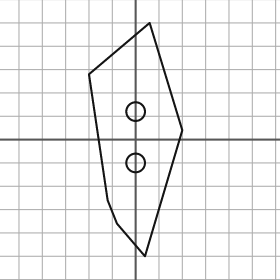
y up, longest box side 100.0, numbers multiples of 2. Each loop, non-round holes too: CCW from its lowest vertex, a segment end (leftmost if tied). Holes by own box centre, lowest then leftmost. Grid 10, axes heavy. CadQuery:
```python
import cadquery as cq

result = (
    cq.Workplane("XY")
    .moveTo(4.0, -50.0)
    .lineTo(20.0, 4.0)
    .lineTo(6.0, 50.0)
    .lineTo(-20.0, 28.0)
    .lineTo(-12.0, -26.0)
    .lineTo(-8.0, -36.0)
    .close()
    .moveTo(0.0, -10.0)
    .circle(4.0)
    .moveTo(0.0, 12.0)
    .circle(4.0)
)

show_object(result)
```